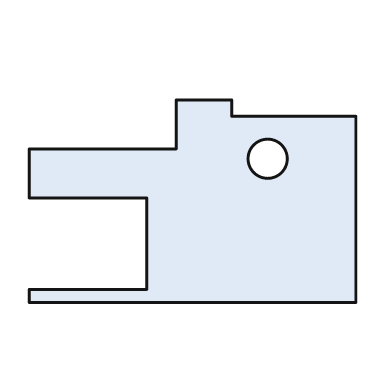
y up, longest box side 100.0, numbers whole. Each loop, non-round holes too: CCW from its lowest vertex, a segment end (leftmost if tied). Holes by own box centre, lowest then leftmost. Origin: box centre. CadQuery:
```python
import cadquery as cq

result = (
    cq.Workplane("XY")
    .moveTo(-50.0, -31.0)
    .lineTo(50.0, -31.0)
    .lineTo(50.0, 26.0)
    .lineTo(12.0, 26.0)
    .lineTo(12.0, 31.0)
    .lineTo(-5.0, 31.0)
    .lineTo(-5.0, 16.0)
    .lineTo(-50.0, 16.0)
    .lineTo(-50.0, 1.0)
    .lineTo(-14.0, 1.0)
    .lineTo(-14.0, -27.0)
    .lineTo(-50.0, -27.0)
    .close()
    .moveTo(23.0, 13.0)
    .circle(6.0)
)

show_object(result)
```